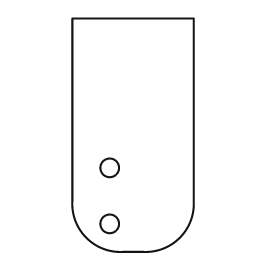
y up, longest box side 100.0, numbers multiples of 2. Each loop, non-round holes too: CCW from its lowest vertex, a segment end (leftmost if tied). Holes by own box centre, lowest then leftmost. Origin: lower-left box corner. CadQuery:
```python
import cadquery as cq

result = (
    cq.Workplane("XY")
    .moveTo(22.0, 0.0)
    .lineTo(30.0, 0.0)
    .threePointArc((46.0, 6.0), (52.0, 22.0))
    .lineTo(52.0, 100.0)
    .lineTo(0.0, 100.0)
    .lineTo(0.0, 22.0)
    .threePointArc((6.0, 6.0), (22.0, 0.0))
    .close()
    .moveTo(16.0, 12.0)
    .circle(4.0)
    .moveTo(16.0, 36.0)
    .circle(4.0)
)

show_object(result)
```